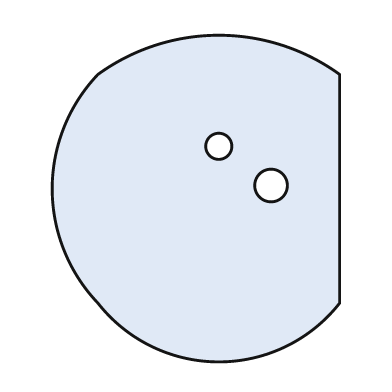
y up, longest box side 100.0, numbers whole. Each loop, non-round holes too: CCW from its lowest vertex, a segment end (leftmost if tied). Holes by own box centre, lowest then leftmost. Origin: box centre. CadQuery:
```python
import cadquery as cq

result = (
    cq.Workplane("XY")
    .moveTo(-30.0, -32.0)
    .threePointArc((7.0, -50.0), (44.0, -32.0))
    .lineTo(44.0, 38.0)
    .threePointArc((7.0, 50.0), (-30.0, 38.0))
    .threePointArc((-44.0, 3.0), (-30.0, -32.0))
    .close()
    .moveTo(23.0, 4.0)
    .circle(5.0)
    .moveTo(7.0, 16.0)
    .circle(4.0)
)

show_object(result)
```